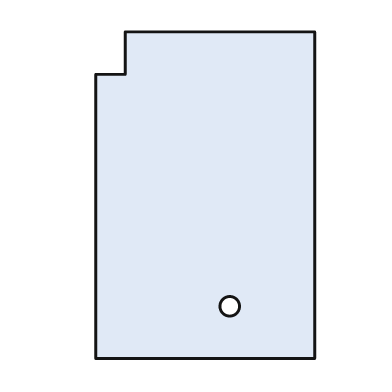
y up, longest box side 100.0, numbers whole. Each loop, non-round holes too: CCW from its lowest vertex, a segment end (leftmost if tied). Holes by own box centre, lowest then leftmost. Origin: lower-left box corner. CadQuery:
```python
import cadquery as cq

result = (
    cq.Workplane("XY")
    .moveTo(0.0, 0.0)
    .lineTo(67.0, 0.0)
    .lineTo(67.0, 100.0)
    .lineTo(9.0, 100.0)
    .lineTo(9.0, 87.0)
    .lineTo(0.0, 87.0)
    .close()
    .moveTo(41.0, 16.0)
    .circle(3.0)
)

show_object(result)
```